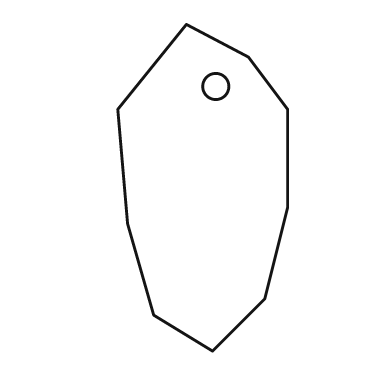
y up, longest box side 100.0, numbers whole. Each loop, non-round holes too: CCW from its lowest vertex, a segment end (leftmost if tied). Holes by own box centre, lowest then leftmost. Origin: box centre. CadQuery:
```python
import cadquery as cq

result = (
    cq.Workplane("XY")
    .moveTo(3.0, -50.0)
    .lineTo(19.0, -34.0)
    .lineTo(26.0, -6.0)
    .lineTo(26.0, 24.0)
    .lineTo(14.0, 40.0)
    .lineTo(-5.0, 50.0)
    .lineTo(-26.0, 24.0)
    .lineTo(-23.0, -11.0)
    .lineTo(-15.0, -39.0)
    .close()
    .moveTo(4.0, 31.0)
    .circle(4.0)
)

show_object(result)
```